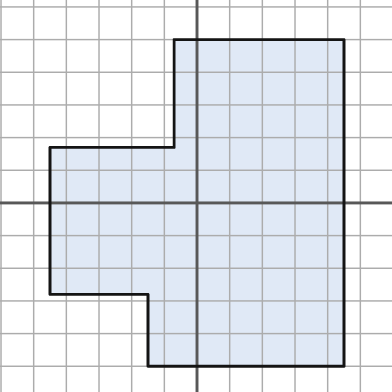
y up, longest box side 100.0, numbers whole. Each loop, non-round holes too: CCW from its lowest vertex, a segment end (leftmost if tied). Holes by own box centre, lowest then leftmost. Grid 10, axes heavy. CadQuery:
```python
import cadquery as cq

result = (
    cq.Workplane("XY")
    .moveTo(-15.0, -50.0)
    .lineTo(45.0, -50.0)
    .lineTo(45.0, 50.0)
    .lineTo(-7.0, 50.0)
    .lineTo(-7.0, 17.0)
    .lineTo(-45.0, 17.0)
    .lineTo(-45.0, -28.0)
    .lineTo(-15.0, -28.0)
    .close()
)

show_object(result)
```